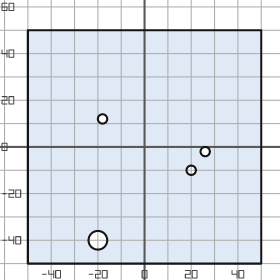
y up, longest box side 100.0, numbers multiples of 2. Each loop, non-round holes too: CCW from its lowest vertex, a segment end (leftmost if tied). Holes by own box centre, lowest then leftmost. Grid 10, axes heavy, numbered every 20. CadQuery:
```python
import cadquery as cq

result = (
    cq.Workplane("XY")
    .moveTo(-50.0, -50.0)
    .lineTo(50.0, -50.0)
    .lineTo(50.0, 50.0)
    .lineTo(-50.0, 50.0)
    .close()
    .moveTo(-20.0, -40.0)
    .circle(4.0)
    .moveTo(20.0, -10.0)
    .circle(2.0)
    .moveTo(26.0, -2.0)
    .circle(2.0)
    .moveTo(-18.0, 12.0)
    .circle(2.0)
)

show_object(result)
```